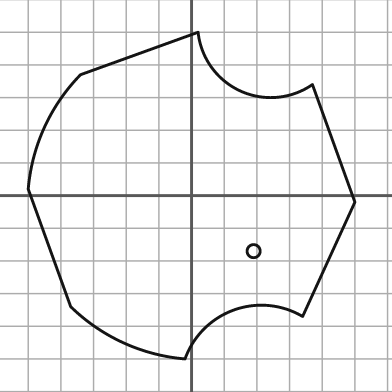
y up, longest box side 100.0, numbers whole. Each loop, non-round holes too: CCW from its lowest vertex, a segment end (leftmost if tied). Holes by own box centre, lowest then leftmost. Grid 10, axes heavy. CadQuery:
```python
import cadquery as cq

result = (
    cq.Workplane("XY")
    .moveTo(-2.0, -50.0)
    .threePointArc((13.0, -35.0), (34.0, -37.0))
    .lineTo(50.0, -2.0)
    .lineTo(37.0, 34.0)
    .threePointArc((15.0, 32.0), (2.0, 50.0))
    .lineTo(-34.0, 37.0)
    .threePointArc((-45.0, 21.0), (-50.0, 2.0))
    .lineTo(-37.0, -34.0)
    .threePointArc((-21.0, -45.0), (-2.0, -50.0))
    .close()
    .moveTo(19.0, -17.0)
    .circle(2.0)
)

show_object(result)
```